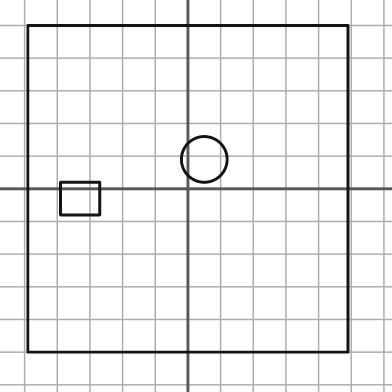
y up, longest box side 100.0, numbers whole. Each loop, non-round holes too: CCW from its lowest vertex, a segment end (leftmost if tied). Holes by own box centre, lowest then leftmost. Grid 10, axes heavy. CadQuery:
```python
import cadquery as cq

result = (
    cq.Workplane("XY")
    .moveTo(-49.0, -50.0)
    .lineTo(49.0, -50.0)
    .lineTo(49.0, 50.0)
    .lineTo(-49.0, 50.0)
    .close()
    .moveTo(-39.0, -8.0)
    .lineTo(-27.0, -8.0)
    .lineTo(-27.0, 2.0)
    .lineTo(-39.0, 2.0)
    .close()
    .moveTo(5.0, 9.0)
    .circle(7.0)
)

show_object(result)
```